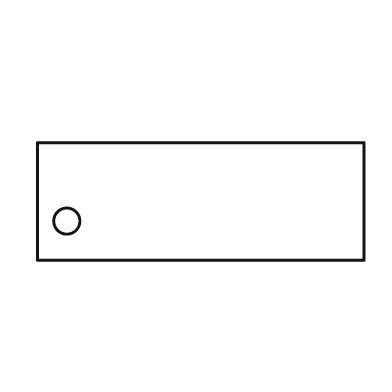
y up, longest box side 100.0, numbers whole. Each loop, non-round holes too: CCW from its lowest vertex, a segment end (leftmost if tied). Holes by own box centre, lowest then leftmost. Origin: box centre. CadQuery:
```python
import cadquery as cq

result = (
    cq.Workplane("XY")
    .moveTo(-50.0, -18.0)
    .lineTo(50.0, -18.0)
    .lineTo(50.0, 18.0)
    .lineTo(-50.0, 18.0)
    .close()
    .moveTo(-41.0, -6.0)
    .circle(4.0)
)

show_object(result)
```